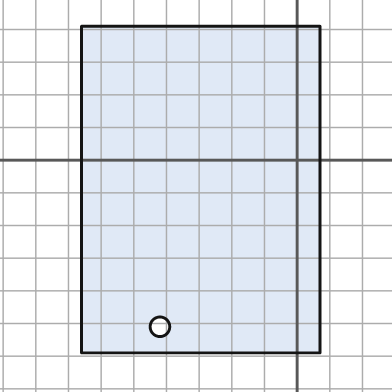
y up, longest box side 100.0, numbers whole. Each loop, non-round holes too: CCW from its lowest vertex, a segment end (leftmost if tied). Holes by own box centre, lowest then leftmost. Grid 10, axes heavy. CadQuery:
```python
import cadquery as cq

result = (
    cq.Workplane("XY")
    .moveTo(-66.0, -59.0)
    .lineTo(7.0, -59.0)
    .lineTo(7.0, 41.0)
    .lineTo(-66.0, 41.0)
    .close()
    .moveTo(-42.0, -51.0)
    .circle(3.0)
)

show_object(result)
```